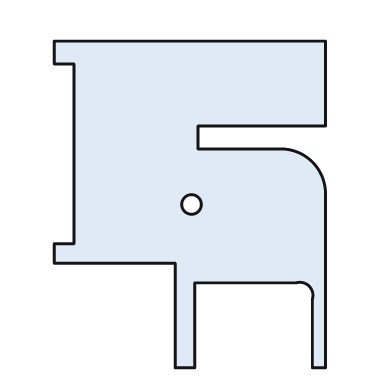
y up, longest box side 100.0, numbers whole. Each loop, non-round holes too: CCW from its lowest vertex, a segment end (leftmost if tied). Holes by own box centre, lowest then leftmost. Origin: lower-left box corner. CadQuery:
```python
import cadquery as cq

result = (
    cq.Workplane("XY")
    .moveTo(37.0, 0.0)
    .lineTo(43.0, 0.0)
    .lineTo(43.0, 26.0)
    .lineTo(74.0, 26.0)
    .threePointArc((78.0, 25.0), (79.0, 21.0))
    .lineTo(79.0, 0.0)
    .lineTo(83.0, 0.0)
    .lineTo(83.0, 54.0)
    .threePointArc((79.0, 63.0), (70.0, 67.0))
    .lineTo(44.0, 67.0)
    .lineTo(44.0, 74.0)
    .lineTo(83.0, 74.0)
    .lineTo(83.0, 100.0)
    .lineTo(0.0, 100.0)
    .lineTo(0.0, 93.0)
    .lineTo(6.0, 93.0)
    .lineTo(6.0, 38.0)
    .lineTo(0.0, 38.0)
    .lineTo(0.0, 32.0)
    .lineTo(37.0, 32.0)
    .close()
    .moveTo(42.0, 50.0)
    .circle(3.0)
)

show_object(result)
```